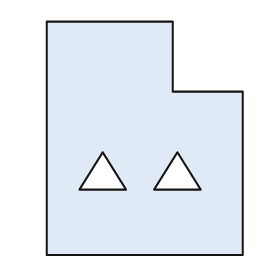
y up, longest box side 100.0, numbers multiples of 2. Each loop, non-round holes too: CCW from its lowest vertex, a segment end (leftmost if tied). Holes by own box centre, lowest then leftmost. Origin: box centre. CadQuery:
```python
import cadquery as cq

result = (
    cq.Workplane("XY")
    .moveTo(-42.0, -50.0)
    .lineTo(42.0, -50.0)
    .lineTo(42.0, 20.0)
    .lineTo(12.0, 20.0)
    .lineTo(12.0, 50.0)
    .lineTo(-42.0, 50.0)
    .close()
    .moveTo(-28.0, -22.0)
    .lineTo(-8.0, -22.0)
    .lineTo(-18.0, -6.0)
    .close()
    .moveTo(4.0, -22.0)
    .lineTo(24.0, -22.0)
    .lineTo(14.0, -6.0)
    .close()
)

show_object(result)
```